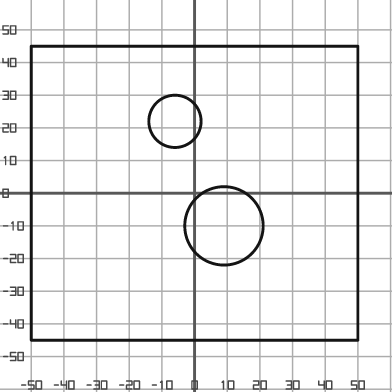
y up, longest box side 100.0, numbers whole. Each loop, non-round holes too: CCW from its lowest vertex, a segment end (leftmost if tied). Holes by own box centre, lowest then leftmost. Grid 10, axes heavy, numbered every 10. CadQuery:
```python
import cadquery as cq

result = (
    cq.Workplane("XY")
    .moveTo(-50.0, -45.0)
    .lineTo(50.0, -45.0)
    .lineTo(50.0, 45.0)
    .lineTo(-50.0, 45.0)
    .close()
    .moveTo(9.0, -10.0)
    .circle(12.0)
    .moveTo(-6.0, 22.0)
    .circle(8.0)
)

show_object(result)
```